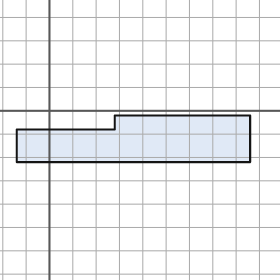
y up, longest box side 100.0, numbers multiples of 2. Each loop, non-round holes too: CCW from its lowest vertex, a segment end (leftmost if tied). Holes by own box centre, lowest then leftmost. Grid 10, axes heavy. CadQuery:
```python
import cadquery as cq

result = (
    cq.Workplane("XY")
    .moveTo(-14.0, -22.0)
    .lineTo(86.0, -22.0)
    .lineTo(86.0, -2.0)
    .lineTo(28.0, -2.0)
    .lineTo(28.0, -8.0)
    .lineTo(-14.0, -8.0)
    .close()
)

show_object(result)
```